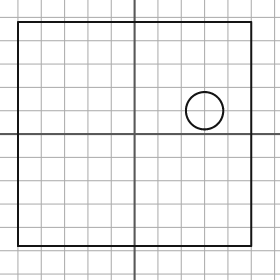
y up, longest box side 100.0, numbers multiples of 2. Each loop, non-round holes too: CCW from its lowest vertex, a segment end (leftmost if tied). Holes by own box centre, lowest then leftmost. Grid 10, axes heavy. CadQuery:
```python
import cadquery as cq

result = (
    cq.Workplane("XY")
    .moveTo(-50.0, -48.0)
    .lineTo(50.0, -48.0)
    .lineTo(50.0, 48.0)
    .lineTo(-50.0, 48.0)
    .close()
    .moveTo(30.0, 10.0)
    .circle(8.0)
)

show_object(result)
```